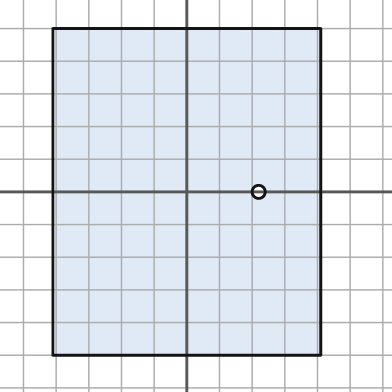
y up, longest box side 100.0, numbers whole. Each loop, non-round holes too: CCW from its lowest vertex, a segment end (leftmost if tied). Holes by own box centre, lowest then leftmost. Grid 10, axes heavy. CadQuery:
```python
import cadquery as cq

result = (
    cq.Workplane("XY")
    .moveTo(-41.0, -50.0)
    .lineTo(41.0, -50.0)
    .lineTo(41.0, 50.0)
    .lineTo(-41.0, 50.0)
    .close()
    .moveTo(22.0, 0.0)
    .circle(2.0)
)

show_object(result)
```